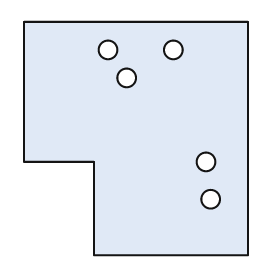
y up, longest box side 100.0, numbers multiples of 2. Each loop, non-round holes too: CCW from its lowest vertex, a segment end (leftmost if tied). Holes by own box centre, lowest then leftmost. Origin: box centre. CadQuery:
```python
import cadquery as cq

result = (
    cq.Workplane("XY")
    .moveTo(-18.0, -50.0)
    .lineTo(48.0, -50.0)
    .lineTo(48.0, 50.0)
    .lineTo(-48.0, 50.0)
    .lineTo(-48.0, -10.0)
    .lineTo(-18.0, -10.0)
    .close()
    .moveTo(32.0, -26.0)
    .circle(4.0)
    .moveTo(30.0, -10.0)
    .circle(4.0)
    .moveTo(-4.0, 26.0)
    .circle(4.0)
    .moveTo(-12.0, 38.0)
    .circle(4.0)
    .moveTo(16.0, 38.0)
    .circle(4.0)
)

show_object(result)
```